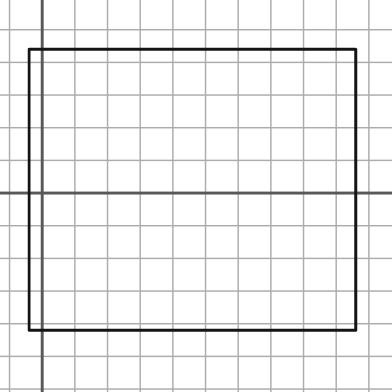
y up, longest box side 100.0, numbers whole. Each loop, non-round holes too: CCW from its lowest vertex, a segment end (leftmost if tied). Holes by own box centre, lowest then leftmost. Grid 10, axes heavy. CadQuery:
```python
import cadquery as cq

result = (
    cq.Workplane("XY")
    .moveTo(-4.0, -42.0)
    .lineTo(96.0, -42.0)
    .lineTo(96.0, 44.0)
    .lineTo(-4.0, 44.0)
    .close()
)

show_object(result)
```